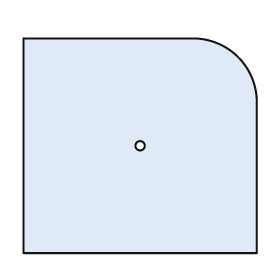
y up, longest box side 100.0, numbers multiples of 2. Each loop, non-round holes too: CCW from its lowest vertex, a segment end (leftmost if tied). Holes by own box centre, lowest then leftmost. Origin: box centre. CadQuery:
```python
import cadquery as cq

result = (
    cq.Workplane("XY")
    .moveTo(-50.0, -46.0)
    .lineTo(50.0, -46.0)
    .lineTo(50.0, 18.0)
    .threePointArc((42.0, 38.0), (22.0, 46.0))
    .lineTo(-50.0, 46.0)
    .close()
    .moveTo(0.0, 0.0)
    .circle(2.0)
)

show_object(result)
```